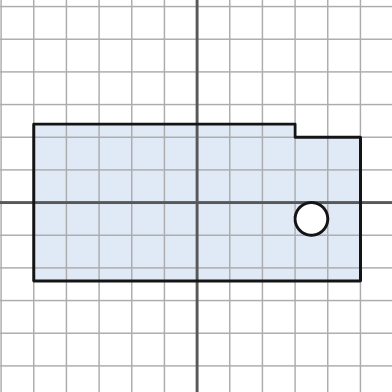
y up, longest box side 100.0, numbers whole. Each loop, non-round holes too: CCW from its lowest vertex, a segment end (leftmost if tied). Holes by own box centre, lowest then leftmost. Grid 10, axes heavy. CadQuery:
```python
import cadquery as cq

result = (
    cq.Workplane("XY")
    .moveTo(-50.0, -24.0)
    .lineTo(50.0, -24.0)
    .lineTo(50.0, 20.0)
    .lineTo(30.0, 20.0)
    .lineTo(30.0, 24.0)
    .lineTo(-50.0, 24.0)
    .close()
    .moveTo(35.0, -5.0)
    .circle(5.0)
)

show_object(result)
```